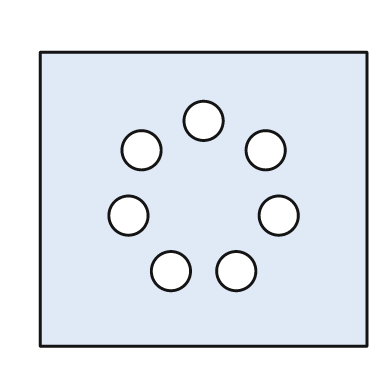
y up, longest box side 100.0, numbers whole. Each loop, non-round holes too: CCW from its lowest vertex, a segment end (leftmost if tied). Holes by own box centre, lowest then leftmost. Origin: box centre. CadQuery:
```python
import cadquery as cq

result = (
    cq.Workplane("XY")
    .moveTo(-50.0, -45.0)
    .lineTo(50.0, -45.0)
    .lineTo(50.0, 45.0)
    .lineTo(-50.0, 45.0)
    .close()
    .moveTo(-10.0, -22.0)
    .circle(6.0)
    .moveTo(10.0, -22.0)
    .circle(6.0)
    .moveTo(-23.0, -5.0)
    .circle(6.0)
    .moveTo(23.0, -5.0)
    .circle(6.0)
    .moveTo(-19.0, 15.0)
    .circle(6.0)
    .moveTo(19.0, 15.0)
    .circle(6.0)
    .moveTo(0.0, 24.0)
    .circle(6.0)
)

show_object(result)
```